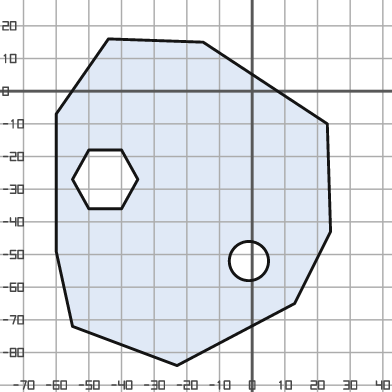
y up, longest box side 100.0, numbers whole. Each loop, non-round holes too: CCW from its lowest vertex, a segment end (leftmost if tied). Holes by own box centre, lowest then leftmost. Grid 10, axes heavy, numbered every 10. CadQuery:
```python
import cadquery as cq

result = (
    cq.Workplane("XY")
    .moveTo(-23.0, -84.0)
    .lineTo(13.0, -65.0)
    .lineTo(24.0, -43.0)
    .lineTo(23.0, -10.0)
    .lineTo(-15.0, 15.0)
    .lineTo(-44.0, 16.0)
    .lineTo(-60.0, -7.0)
    .lineTo(-60.0, -49.0)
    .lineTo(-55.0, -72.0)
    .close()
    .moveTo(-1.0, -52.0)
    .circle(6.0)
    .moveTo(-50.0, -36.0)
    .lineTo(-40.0, -36.0)
    .lineTo(-35.0, -27.0)
    .lineTo(-40.0, -18.0)
    .lineTo(-50.0, -18.0)
    .lineTo(-55.0, -27.0)
    .close()
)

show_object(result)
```